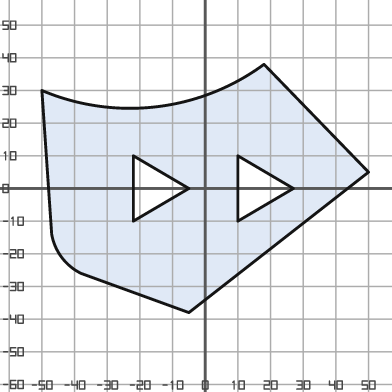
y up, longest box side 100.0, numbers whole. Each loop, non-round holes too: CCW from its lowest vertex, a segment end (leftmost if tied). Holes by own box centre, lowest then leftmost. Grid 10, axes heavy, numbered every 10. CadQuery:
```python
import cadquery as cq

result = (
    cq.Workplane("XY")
    .moveTo(-5.0, -38.0)
    .lineTo(50.0, 5.0)
    .lineTo(18.0, 38.0)
    .threePointArc((-15.0, 25.0), (-50.0, 30.0))
    .lineTo(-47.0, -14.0)
    .threePointArc((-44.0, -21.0), (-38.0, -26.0))
    .close()
    .moveTo(-22.0, -10.0)
    .lineTo(-5.0, 0.0)
    .lineTo(-22.0, 10.0)
    .close()
    .moveTo(10.0, -10.0)
    .lineTo(27.0, 0.0)
    .lineTo(10.0, 10.0)
    .close()
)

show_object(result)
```